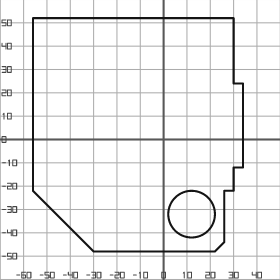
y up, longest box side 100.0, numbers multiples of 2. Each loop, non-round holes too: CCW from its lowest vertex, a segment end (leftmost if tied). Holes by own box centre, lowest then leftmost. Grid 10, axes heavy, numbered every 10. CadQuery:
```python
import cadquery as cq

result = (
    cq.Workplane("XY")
    .moveTo(-30.0, -48.0)
    .lineTo(22.0, -48.0)
    .lineTo(26.0, -44.0)
    .lineTo(26.0, -22.0)
    .lineTo(30.0, -22.0)
    .lineTo(30.0, -12.0)
    .lineTo(34.0, -12.0)
    .lineTo(34.0, 24.0)
    .lineTo(30.0, 24.0)
    .lineTo(30.0, 52.0)
    .lineTo(-56.0, 52.0)
    .lineTo(-56.0, -22.0)
    .close()
    .moveTo(12.0, -32.0)
    .circle(10.0)
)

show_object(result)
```